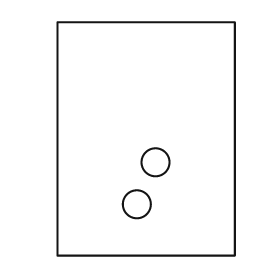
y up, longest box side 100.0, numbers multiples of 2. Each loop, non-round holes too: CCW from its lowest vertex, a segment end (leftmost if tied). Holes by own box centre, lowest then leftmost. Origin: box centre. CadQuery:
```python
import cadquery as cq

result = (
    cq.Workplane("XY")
    .moveTo(-38.0, -50.0)
    .lineTo(38.0, -50.0)
    .lineTo(38.0, 50.0)
    .lineTo(-38.0, 50.0)
    .close()
    .moveTo(-4.0, -28.0)
    .circle(6.0)
    .moveTo(4.0, -10.0)
    .circle(6.0)
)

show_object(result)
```